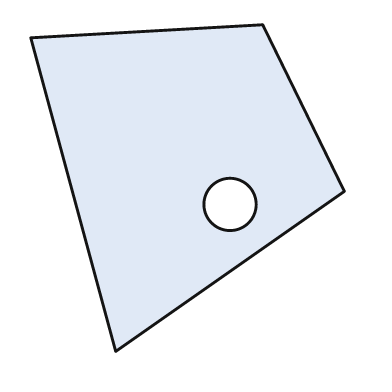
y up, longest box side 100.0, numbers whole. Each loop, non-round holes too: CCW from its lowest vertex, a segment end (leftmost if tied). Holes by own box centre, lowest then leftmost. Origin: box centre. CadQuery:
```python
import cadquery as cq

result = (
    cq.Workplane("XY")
    .moveTo(-22.0, -50.0)
    .lineTo(48.0, -1.0)
    .lineTo(23.0, 50.0)
    .lineTo(-48.0, 46.0)
    .close()
    .moveTo(13.0, -5.0)
    .circle(8.0)
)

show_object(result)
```